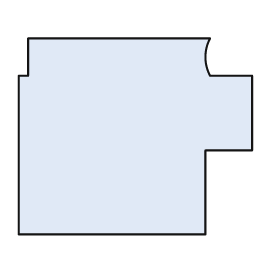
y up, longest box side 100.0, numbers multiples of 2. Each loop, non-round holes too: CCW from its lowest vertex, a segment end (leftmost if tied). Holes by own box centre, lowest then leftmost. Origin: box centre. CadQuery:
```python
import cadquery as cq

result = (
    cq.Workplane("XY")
    .moveTo(-50.0, -42.0)
    .lineTo(30.0, -42.0)
    .lineTo(30.0, -6.0)
    .lineTo(50.0, -6.0)
    .lineTo(50.0, 26.0)
    .lineTo(32.0, 26.0)
    .threePointArc((30.0, 34.0), (32.0, 42.0))
    .lineTo(-46.0, 42.0)
    .lineTo(-46.0, 26.0)
    .lineTo(-50.0, 26.0)
    .close()
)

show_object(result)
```